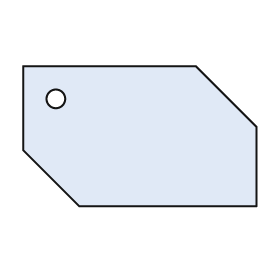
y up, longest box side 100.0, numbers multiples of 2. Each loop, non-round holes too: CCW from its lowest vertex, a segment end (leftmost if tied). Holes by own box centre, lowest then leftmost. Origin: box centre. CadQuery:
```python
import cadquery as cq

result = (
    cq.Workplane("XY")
    .moveTo(-26.0, -30.0)
    .lineTo(50.0, -30.0)
    .lineTo(50.0, 4.0)
    .lineTo(24.0, 30.0)
    .lineTo(-50.0, 30.0)
    .lineTo(-50.0, -6.0)
    .close()
    .moveTo(-36.0, 16.0)
    .circle(4.0)
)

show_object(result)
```